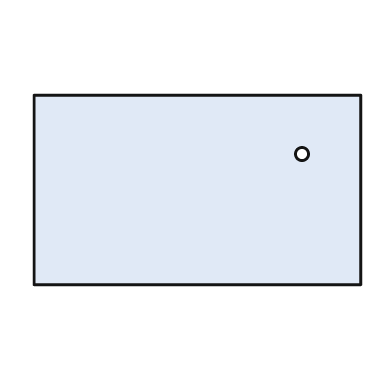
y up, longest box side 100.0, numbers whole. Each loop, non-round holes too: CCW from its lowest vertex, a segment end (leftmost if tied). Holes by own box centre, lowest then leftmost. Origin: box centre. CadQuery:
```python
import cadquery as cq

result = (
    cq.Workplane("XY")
    .moveTo(-50.0, -29.0)
    .lineTo(50.0, -29.0)
    .lineTo(50.0, 29.0)
    .lineTo(-50.0, 29.0)
    .close()
    .moveTo(32.0, 11.0)
    .circle(2.0)
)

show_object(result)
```